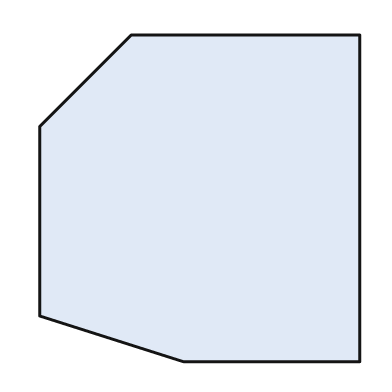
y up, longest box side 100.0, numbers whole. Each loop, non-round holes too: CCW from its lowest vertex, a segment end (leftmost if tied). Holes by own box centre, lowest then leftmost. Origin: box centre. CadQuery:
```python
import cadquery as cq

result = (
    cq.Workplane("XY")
    .moveTo(-5.0, -50.0)
    .lineTo(49.0, -50.0)
    .lineTo(49.0, 50.0)
    .lineTo(-21.0, 50.0)
    .lineTo(-49.0, 22.0)
    .lineTo(-49.0, -36.0)
    .close()
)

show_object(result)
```